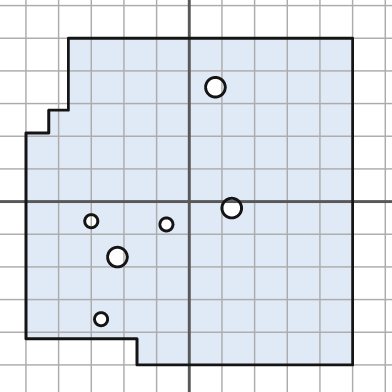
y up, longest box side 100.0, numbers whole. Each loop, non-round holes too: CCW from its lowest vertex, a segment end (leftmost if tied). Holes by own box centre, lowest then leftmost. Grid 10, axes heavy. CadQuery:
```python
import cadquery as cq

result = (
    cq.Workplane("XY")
    .moveTo(-16.0, -50.0)
    .lineTo(50.0, -50.0)
    .lineTo(50.0, 50.0)
    .lineTo(-37.0, 50.0)
    .lineTo(-37.0, 28.0)
    .lineTo(-43.0, 28.0)
    .lineTo(-43.0, 21.0)
    .lineTo(-50.0, 21.0)
    .lineTo(-50.0, -42.0)
    .lineTo(-16.0, -42.0)
    .close()
    .moveTo(-27.0, -36.0)
    .circle(2.0)
    .moveTo(-22.0, -17.0)
    .circle(3.0)
    .moveTo(-7.0, -7.0)
    .circle(2.0)
    .moveTo(-30.0, -6.0)
    .circle(2.0)
    .moveTo(13.0, -2.0)
    .circle(3.0)
    .moveTo(8.0, 35.0)
    .circle(3.0)
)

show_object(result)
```